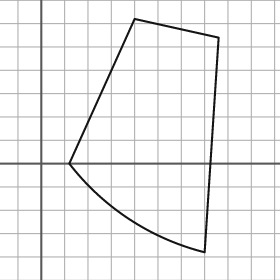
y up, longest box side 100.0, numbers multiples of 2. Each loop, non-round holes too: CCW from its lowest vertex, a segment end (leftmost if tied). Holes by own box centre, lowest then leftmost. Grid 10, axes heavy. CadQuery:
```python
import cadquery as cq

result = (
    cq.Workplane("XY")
    .moveTo(70.0, -38.0)
    .lineTo(76.0, 54.0)
    .lineTo(40.0, 62.0)
    .lineTo(12.0, 0.0)
    .threePointArc((38.0, -24.0), (70.0, -38.0))
    .close()
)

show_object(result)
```